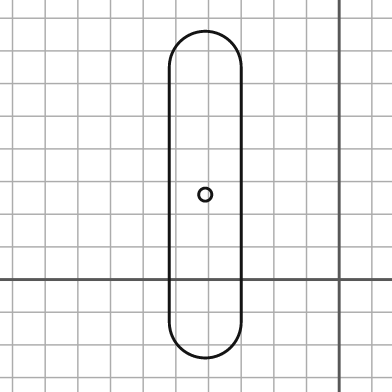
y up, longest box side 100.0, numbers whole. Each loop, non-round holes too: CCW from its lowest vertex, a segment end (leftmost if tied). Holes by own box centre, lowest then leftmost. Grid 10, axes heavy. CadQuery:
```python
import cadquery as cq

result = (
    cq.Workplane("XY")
    .moveTo(-52.0, -13.0)
    .threePointArc((-41.0, -24.0), (-30.0, -13.0))
    .lineTo(-30.0, 65.0)
    .threePointArc((-41.0, 76.0), (-52.0, 65.0))
    .close()
    .moveTo(-41.0, 26.0)
    .circle(2.0)
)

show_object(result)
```